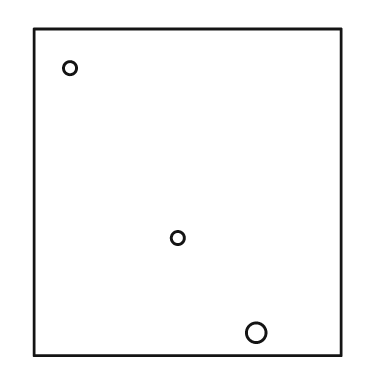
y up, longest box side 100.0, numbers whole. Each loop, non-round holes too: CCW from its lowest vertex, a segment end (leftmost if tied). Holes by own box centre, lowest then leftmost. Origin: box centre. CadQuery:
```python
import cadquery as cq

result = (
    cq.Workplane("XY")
    .moveTo(-47.0, -50.0)
    .lineTo(47.0, -50.0)
    .lineTo(47.0, 50.0)
    .lineTo(-47.0, 50.0)
    .close()
    .moveTo(21.0, -43.0)
    .circle(3.0)
    .moveTo(-3.0, -14.0)
    .circle(2.0)
    .moveTo(-36.0, 38.0)
    .circle(2.0)
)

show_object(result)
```